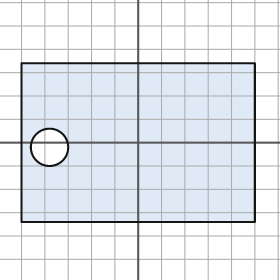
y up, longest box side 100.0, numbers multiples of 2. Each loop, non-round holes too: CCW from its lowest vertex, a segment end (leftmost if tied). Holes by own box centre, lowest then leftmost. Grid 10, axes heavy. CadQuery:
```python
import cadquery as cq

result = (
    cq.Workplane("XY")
    .moveTo(-50.0, -34.0)
    .lineTo(50.0, -34.0)
    .lineTo(50.0, 34.0)
    .lineTo(-50.0, 34.0)
    .close()
    .moveTo(-38.0, -2.0)
    .circle(8.0)
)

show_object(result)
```